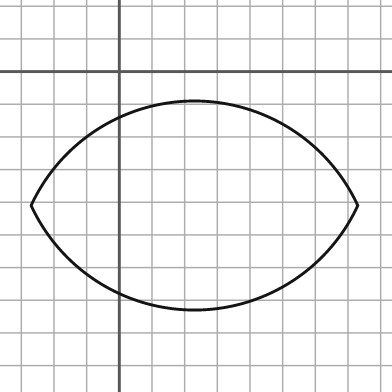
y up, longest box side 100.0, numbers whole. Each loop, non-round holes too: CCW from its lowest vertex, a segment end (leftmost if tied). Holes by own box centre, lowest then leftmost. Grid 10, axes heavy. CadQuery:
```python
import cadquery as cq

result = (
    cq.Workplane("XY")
    .moveTo(-27.0, -41.0)
    .threePointArc((23.0, -73.0), (73.0, -41.0))
    .threePointArc((23.0, -9.0), (-27.0, -41.0))
    .close()
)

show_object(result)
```